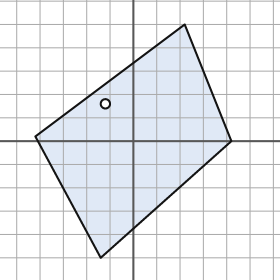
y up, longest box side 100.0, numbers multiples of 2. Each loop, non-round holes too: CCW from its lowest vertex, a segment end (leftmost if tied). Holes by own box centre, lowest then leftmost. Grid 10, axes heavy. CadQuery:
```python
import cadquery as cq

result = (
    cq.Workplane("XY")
    .moveTo(-14.0, -50.0)
    .lineTo(42.0, 0.0)
    .lineTo(22.0, 50.0)
    .lineTo(-42.0, 2.0)
    .close()
    .moveTo(-12.0, 16.0)
    .circle(2.0)
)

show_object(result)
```